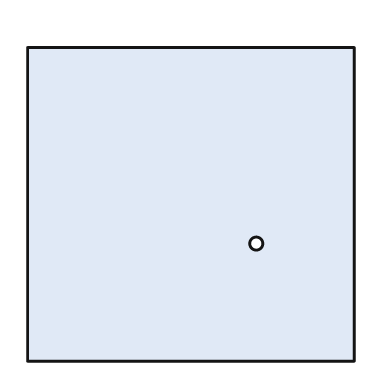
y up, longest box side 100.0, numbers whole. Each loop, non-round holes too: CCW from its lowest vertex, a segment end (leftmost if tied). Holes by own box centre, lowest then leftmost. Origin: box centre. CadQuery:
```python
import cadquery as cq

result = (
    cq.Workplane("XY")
    .moveTo(-50.0, -48.0)
    .lineTo(50.0, -48.0)
    .lineTo(50.0, 48.0)
    .lineTo(-50.0, 48.0)
    .close()
    .moveTo(20.0, -12.0)
    .circle(2.0)
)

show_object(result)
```